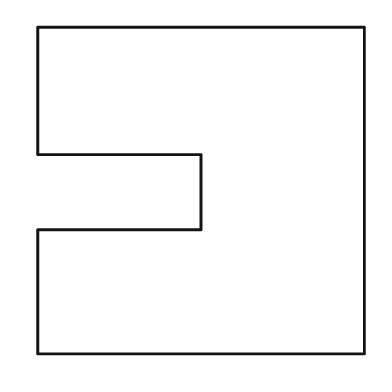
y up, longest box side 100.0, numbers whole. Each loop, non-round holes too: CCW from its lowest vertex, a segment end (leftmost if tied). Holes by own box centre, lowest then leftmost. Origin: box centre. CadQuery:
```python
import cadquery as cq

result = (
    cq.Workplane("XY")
    .moveTo(-50.0, -50.0)
    .lineTo(50.0, -50.0)
    .lineTo(50.0, 50.0)
    .lineTo(-50.0, 50.0)
    .lineTo(-50.0, 11.0)
    .lineTo(0.0, 11.0)
    .lineTo(0.0, -12.0)
    .lineTo(-50.0, -12.0)
    .close()
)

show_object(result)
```